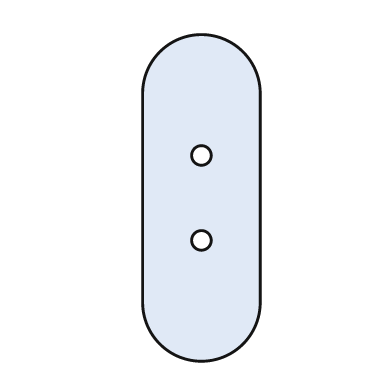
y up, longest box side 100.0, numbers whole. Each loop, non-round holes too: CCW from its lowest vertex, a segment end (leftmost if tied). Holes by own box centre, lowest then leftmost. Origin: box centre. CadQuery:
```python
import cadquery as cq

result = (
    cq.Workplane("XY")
    .moveTo(-18.0, -32.0)
    .threePointArc((0.0, -50.0), (18.0, -32.0))
    .lineTo(18.0, 32.0)
    .threePointArc((0.0, 50.0), (-18.0, 32.0))
    .close()
    .moveTo(0.0, -13.0)
    .circle(3.0)
    .moveTo(0.0, 13.0)
    .circle(3.0)
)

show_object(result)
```